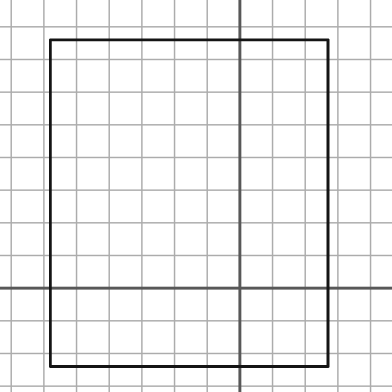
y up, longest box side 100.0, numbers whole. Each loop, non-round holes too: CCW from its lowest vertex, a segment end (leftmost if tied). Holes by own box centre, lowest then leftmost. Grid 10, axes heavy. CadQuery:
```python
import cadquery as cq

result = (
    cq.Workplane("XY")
    .moveTo(-58.0, -24.0)
    .lineTo(27.0, -24.0)
    .lineTo(27.0, 76.0)
    .lineTo(-58.0, 76.0)
    .close()
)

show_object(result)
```